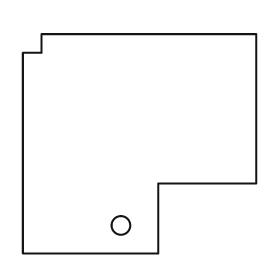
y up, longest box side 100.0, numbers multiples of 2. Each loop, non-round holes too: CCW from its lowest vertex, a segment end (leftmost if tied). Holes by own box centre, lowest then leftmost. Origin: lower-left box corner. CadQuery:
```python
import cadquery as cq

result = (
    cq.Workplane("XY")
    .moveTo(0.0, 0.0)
    .lineTo(58.0, 0.0)
    .lineTo(58.0, 30.0)
    .lineTo(100.0, 30.0)
    .lineTo(100.0, 94.0)
    .lineTo(8.0, 94.0)
    .lineTo(8.0, 86.0)
    .lineTo(0.0, 86.0)
    .close()
    .moveTo(42.0, 12.0)
    .circle(4.0)
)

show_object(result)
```